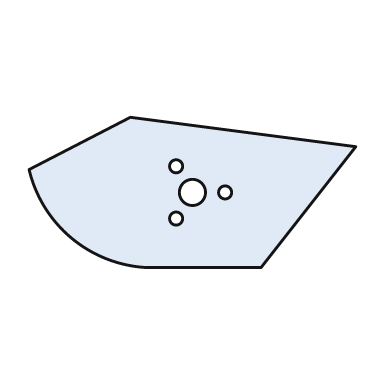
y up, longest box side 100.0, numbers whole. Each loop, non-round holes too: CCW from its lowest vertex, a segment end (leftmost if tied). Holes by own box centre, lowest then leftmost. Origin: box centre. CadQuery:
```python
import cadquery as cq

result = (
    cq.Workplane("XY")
    .moveTo(-14.0, -23.0)
    .lineTo(21.0, -23.0)
    .lineTo(50.0, 14.0)
    .lineTo(-19.0, 23.0)
    .lineTo(-50.0, 7.0)
    .threePointArc((-37.0, -14.0), (-14.0, -23.0))
    .close()
    .moveTo(-5.0, -8.0)
    .circle(2.0)
    .moveTo(0.0, 0.0)
    .circle(4.0)
    .moveTo(10.0, 0.0)
    .circle(2.0)
    .moveTo(-5.0, 8.0)
    .circle(2.0)
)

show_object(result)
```